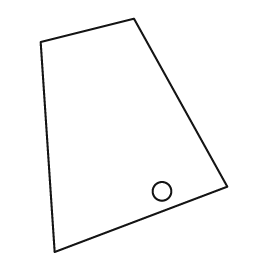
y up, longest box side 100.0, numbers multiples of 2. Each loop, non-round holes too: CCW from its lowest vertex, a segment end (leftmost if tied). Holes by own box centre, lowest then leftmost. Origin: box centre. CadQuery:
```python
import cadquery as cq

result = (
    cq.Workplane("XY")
    .moveTo(-34.0, -50.0)
    .lineTo(40.0, -22.0)
    .lineTo(0.0, 50.0)
    .lineTo(-40.0, 40.0)
    .close()
    .moveTo(12.0, -24.0)
    .circle(4.0)
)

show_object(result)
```